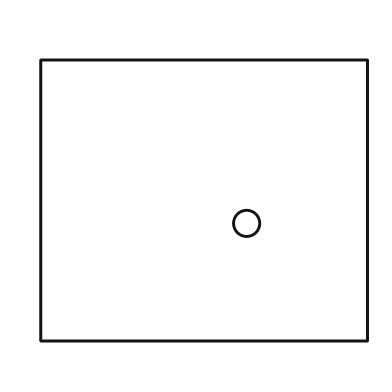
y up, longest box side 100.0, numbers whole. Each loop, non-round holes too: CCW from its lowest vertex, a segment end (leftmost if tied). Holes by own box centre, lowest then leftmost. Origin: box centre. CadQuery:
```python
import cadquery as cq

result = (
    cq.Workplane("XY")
    .moveTo(-50.0, -43.0)
    .lineTo(50.0, -43.0)
    .lineTo(50.0, 43.0)
    .lineTo(-50.0, 43.0)
    .close()
    .moveTo(13.0, -7.0)
    .circle(4.0)
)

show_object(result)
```